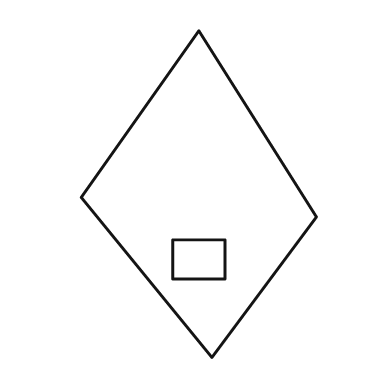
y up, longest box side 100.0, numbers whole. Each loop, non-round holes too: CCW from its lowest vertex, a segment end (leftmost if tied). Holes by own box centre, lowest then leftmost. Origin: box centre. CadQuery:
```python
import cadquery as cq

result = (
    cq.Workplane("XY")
    .moveTo(4.0, -50.0)
    .lineTo(36.0, -7.0)
    .lineTo(0.0, 50.0)
    .lineTo(-36.0, -1.0)
    .close()
    .moveTo(-8.0, -26.0)
    .lineTo(8.0, -26.0)
    .lineTo(8.0, -14.0)
    .lineTo(-8.0, -14.0)
    .close()
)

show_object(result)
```